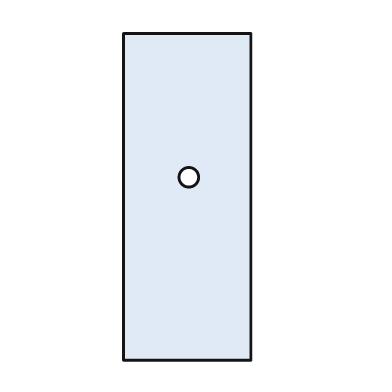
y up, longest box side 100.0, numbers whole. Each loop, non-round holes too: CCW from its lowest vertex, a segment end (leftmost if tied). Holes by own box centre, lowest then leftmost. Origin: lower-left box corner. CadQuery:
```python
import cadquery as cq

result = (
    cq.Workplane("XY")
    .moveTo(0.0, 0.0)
    .lineTo(39.0, 0.0)
    .lineTo(39.0, 100.0)
    .lineTo(0.0, 100.0)
    .close()
    .moveTo(20.0, 56.0)
    .circle(3.0)
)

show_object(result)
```